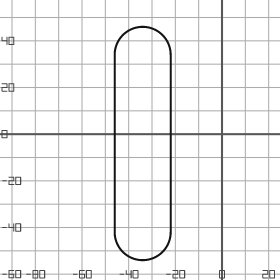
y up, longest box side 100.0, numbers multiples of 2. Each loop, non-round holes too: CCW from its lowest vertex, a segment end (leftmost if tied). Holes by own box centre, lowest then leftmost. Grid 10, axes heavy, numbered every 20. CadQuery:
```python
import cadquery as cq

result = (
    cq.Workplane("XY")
    .moveTo(-46.0, -42.0)
    .threePointArc((-34.0, -54.0), (-22.0, -42.0))
    .lineTo(-22.0, 34.0)
    .threePointArc((-34.0, 46.0), (-46.0, 34.0))
    .close()
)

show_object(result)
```